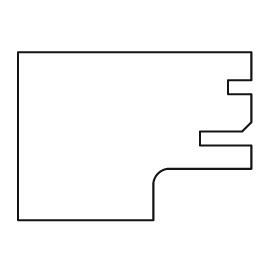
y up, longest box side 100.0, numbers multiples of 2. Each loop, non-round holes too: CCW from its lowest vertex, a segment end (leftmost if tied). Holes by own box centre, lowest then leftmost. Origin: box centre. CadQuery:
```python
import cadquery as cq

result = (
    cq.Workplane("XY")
    .moveTo(-50.0, -36.0)
    .lineTo(8.0, -36.0)
    .lineTo(8.0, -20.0)
    .threePointArc((10.0, -16.0), (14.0, -14.0))
    .lineTo(50.0, -14.0)
    .lineTo(50.0, -4.0)
    .lineTo(28.0, -4.0)
    .lineTo(28.0, 2.0)
    .lineTo(46.0, 2.0)
    .lineTo(50.0, 6.0)
    .lineTo(50.0, 18.0)
    .lineTo(40.0, 18.0)
    .lineTo(40.0, 24.0)
    .lineTo(50.0, 24.0)
    .lineTo(50.0, 36.0)
    .lineTo(-50.0, 36.0)
    .close()
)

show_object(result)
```